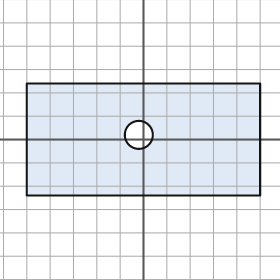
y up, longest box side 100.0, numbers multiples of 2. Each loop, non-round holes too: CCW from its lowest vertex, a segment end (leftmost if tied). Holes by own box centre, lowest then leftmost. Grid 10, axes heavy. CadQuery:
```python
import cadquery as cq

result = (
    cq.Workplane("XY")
    .moveTo(-50.0, -24.0)
    .lineTo(50.0, -24.0)
    .lineTo(50.0, 24.0)
    .lineTo(-50.0, 24.0)
    .close()
    .moveTo(-2.0, 2.0)
    .circle(6.0)
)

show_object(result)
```